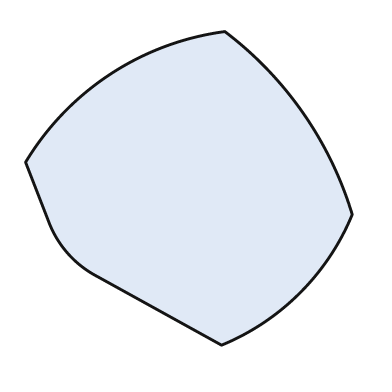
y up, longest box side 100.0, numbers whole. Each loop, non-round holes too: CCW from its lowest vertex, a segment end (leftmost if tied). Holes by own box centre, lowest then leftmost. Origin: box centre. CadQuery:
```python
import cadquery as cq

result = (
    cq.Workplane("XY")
    .moveTo(10.0, -48.0)
    .threePointArc((34.0, -32.0), (50.0, -8.0))
    .threePointArc((35.0, 23.0), (11.0, 48.0))
    .threePointArc((-24.0, 35.0), (-50.0, 8.0))
    .lineTo(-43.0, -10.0)
    .threePointArc((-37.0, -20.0), (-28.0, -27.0))
    .close()
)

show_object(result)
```